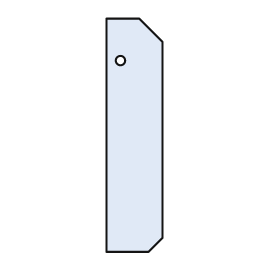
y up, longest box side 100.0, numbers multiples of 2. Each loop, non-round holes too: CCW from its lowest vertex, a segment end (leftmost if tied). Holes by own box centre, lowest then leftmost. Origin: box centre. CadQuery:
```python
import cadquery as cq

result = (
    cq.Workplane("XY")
    .moveTo(-12.0, -50.0)
    .lineTo(6.0, -50.0)
    .lineTo(12.0, -44.0)
    .lineTo(12.0, 40.0)
    .lineTo(2.0, 50.0)
    .lineTo(-12.0, 50.0)
    .close()
    .moveTo(-6.0, 32.0)
    .circle(2.0)
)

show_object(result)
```